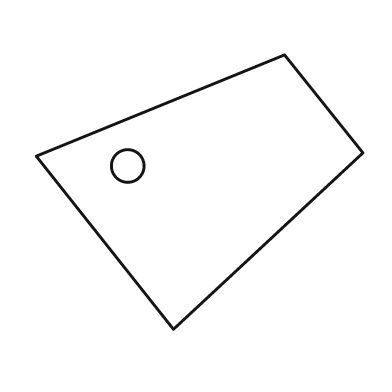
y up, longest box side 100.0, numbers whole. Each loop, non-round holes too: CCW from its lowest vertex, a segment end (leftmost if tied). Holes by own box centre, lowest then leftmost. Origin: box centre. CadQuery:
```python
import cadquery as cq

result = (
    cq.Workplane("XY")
    .moveTo(-8.0, -42.0)
    .lineTo(50.0, 12.0)
    .lineTo(26.0, 42.0)
    .lineTo(-50.0, 11.0)
    .close()
    .moveTo(-22.0, 8.0)
    .circle(5.0)
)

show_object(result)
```